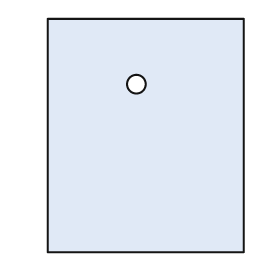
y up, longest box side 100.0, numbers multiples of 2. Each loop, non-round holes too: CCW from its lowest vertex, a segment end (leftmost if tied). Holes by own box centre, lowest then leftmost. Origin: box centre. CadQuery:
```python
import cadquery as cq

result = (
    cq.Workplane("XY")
    .moveTo(-42.0, -50.0)
    .lineTo(42.0, -50.0)
    .lineTo(42.0, 50.0)
    .lineTo(-42.0, 50.0)
    .close()
    .moveTo(-4.0, 22.0)
    .circle(4.0)
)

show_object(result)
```